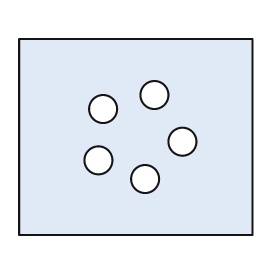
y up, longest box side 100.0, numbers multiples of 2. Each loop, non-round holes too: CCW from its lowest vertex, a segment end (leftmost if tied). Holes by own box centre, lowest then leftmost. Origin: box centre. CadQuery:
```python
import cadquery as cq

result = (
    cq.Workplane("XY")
    .moveTo(-50.0, -42.0)
    .lineTo(50.0, -42.0)
    .lineTo(50.0, 42.0)
    .lineTo(-50.0, 42.0)
    .close()
    .moveTo(4.0, -18.0)
    .circle(6.0)
    .moveTo(-16.0, -10.0)
    .circle(6.0)
    .moveTo(20.0, -2.0)
    .circle(6.0)
    .moveTo(-14.0, 12.0)
    .circle(6.0)
    .moveTo(8.0, 18.0)
    .circle(6.0)
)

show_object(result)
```